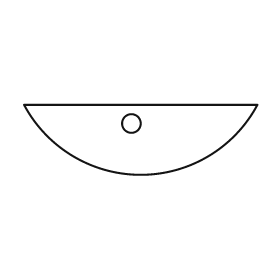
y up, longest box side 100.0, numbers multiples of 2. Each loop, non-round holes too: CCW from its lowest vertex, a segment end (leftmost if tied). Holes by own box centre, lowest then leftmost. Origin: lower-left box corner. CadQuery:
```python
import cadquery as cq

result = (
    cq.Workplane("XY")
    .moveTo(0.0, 30.0)
    .threePointArc((50.0, 0.0), (100.0, 30.0))
    .close()
    .moveTo(46.0, 22.0)
    .circle(4.0)
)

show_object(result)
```